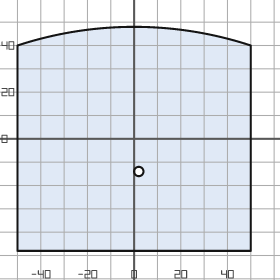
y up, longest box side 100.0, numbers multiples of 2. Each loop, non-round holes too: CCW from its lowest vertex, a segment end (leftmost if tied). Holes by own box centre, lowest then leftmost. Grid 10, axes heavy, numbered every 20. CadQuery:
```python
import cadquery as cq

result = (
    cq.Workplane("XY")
    .moveTo(-50.0, -48.0)
    .lineTo(50.0, -48.0)
    .lineTo(50.0, 40.0)
    .threePointArc((0.0, 48.0), (-50.0, 40.0))
    .close()
    .moveTo(2.0, -14.0)
    .circle(2.0)
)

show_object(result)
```